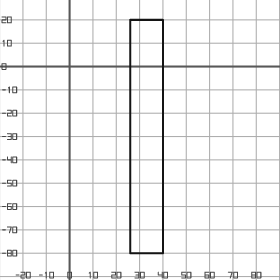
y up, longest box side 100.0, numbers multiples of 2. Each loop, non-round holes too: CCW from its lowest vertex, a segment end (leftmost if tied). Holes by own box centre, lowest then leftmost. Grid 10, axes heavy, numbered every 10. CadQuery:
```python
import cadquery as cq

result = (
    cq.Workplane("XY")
    .moveTo(26.0, -80.0)
    .lineTo(40.0, -80.0)
    .lineTo(40.0, 20.0)
    .lineTo(26.0, 20.0)
    .close()
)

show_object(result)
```